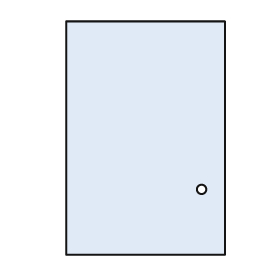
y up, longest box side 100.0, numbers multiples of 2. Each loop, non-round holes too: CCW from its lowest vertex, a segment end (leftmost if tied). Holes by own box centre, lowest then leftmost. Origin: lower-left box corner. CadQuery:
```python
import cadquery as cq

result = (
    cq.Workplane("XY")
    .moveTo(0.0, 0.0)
    .lineTo(68.0, 0.0)
    .lineTo(68.0, 100.0)
    .lineTo(0.0, 100.0)
    .close()
    .moveTo(58.0, 28.0)
    .circle(2.0)
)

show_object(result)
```